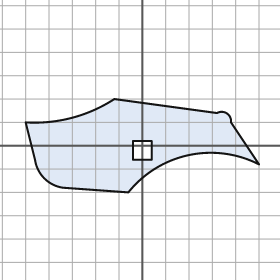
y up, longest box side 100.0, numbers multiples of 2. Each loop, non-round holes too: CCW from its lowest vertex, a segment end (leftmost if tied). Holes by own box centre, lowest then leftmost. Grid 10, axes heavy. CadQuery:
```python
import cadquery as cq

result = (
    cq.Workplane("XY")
    .moveTo(-6.0, -20.0)
    .threePointArc((20.0, -4.0), (50.0, -8.0))
    .lineTo(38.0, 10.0)
    .threePointArc((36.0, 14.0), (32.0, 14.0))
    .lineTo(-12.0, 20.0)
    .threePointArc((-30.0, 12.0), (-50.0, 10.0))
    .lineTo(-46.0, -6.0)
    .threePointArc((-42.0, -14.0), (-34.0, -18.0))
    .close()
    .moveTo(-4.0, -6.0)
    .lineTo(4.0, -6.0)
    .lineTo(4.0, 2.0)
    .lineTo(-4.0, 2.0)
    .close()
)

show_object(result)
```